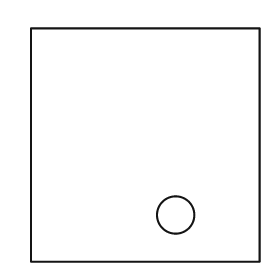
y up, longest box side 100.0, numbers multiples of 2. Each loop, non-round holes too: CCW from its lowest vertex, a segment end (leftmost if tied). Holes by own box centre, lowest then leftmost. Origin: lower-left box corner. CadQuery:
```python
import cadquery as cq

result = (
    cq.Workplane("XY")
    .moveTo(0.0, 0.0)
    .lineTo(98.0, 0.0)
    .lineTo(98.0, 100.0)
    .lineTo(0.0, 100.0)
    .close()
    .moveTo(62.0, 20.0)
    .circle(8.0)
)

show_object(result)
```